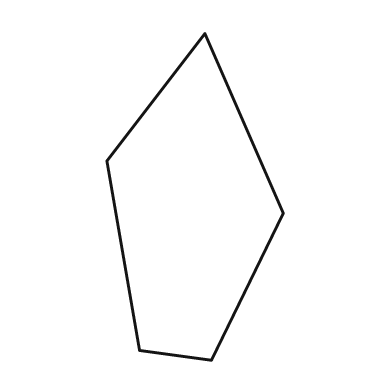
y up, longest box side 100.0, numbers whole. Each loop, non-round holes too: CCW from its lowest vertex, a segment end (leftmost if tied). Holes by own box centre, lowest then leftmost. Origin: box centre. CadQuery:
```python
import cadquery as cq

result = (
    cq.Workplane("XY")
    .moveTo(5.0, -50.0)
    .lineTo(27.0, -5.0)
    .lineTo(3.0, 50.0)
    .lineTo(-27.0, 11.0)
    .lineTo(-17.0, -47.0)
    .close()
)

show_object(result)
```